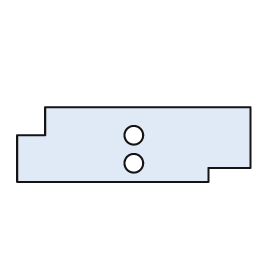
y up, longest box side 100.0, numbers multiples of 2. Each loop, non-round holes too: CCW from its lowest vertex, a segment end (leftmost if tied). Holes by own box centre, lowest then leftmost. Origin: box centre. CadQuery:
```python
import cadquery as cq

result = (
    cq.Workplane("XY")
    .moveTo(-50.0, -16.0)
    .lineTo(32.0, -16.0)
    .lineTo(32.0, -10.0)
    .lineTo(50.0, -10.0)
    .lineTo(50.0, 16.0)
    .lineTo(-38.0, 16.0)
    .lineTo(-38.0, 4.0)
    .lineTo(-50.0, 4.0)
    .close()
    .moveTo(0.0, -8.0)
    .circle(4.0)
    .moveTo(0.0, 4.0)
    .circle(4.0)
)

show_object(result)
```